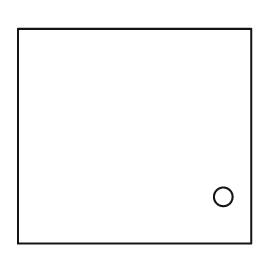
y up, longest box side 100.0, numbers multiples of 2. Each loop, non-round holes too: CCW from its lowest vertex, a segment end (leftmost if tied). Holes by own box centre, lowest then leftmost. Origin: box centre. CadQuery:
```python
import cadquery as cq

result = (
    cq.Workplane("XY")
    .moveTo(-50.0, -46.0)
    .lineTo(50.0, -46.0)
    .lineTo(50.0, 46.0)
    .lineTo(-50.0, 46.0)
    .close()
    .moveTo(38.0, -26.0)
    .circle(4.0)
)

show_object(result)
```